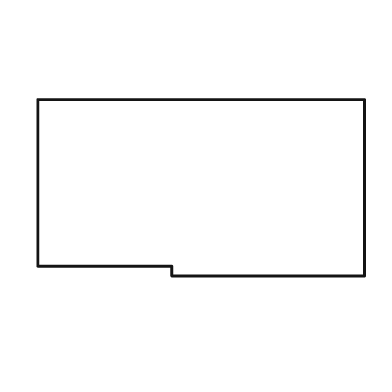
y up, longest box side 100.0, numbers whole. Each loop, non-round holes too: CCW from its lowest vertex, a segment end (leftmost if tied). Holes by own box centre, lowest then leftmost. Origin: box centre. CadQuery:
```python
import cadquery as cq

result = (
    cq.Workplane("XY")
    .moveTo(-9.0, -27.0)
    .lineTo(50.0, -27.0)
    .lineTo(50.0, 27.0)
    .lineTo(-50.0, 27.0)
    .lineTo(-50.0, -24.0)
    .lineTo(-9.0, -24.0)
    .close()
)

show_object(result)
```